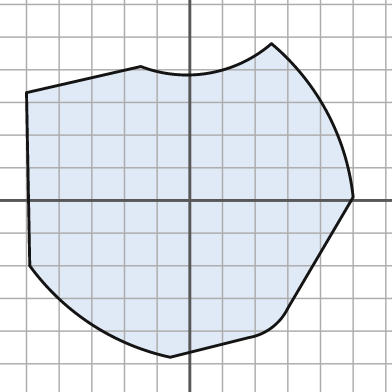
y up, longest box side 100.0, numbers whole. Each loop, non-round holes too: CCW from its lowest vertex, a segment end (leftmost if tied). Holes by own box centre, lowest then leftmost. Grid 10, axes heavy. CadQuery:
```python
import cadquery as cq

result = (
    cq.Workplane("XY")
    .moveTo(-6.0, -48.0)
    .lineTo(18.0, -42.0)
    .threePointArc((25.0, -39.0), (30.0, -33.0))
    .lineTo(50.0, 1.0)
    .threePointArc((42.0, 27.0), (25.0, 48.0))
    .threePointArc((6.0, 39.0), (-15.0, 41.0))
    .lineTo(-50.0, 33.0)
    .lineTo(-49.0, -20.0)
    .threePointArc((-30.0, -38.0), (-6.0, -48.0))
    .close()
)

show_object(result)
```